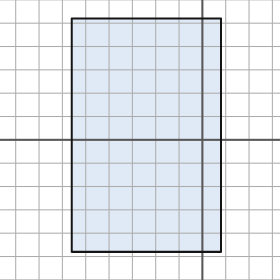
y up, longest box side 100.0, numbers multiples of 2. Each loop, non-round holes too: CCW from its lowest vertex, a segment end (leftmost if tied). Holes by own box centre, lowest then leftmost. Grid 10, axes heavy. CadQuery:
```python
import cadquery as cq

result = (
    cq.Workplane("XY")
    .moveTo(-56.0, -48.0)
    .lineTo(8.0, -48.0)
    .lineTo(8.0, 52.0)
    .lineTo(-56.0, 52.0)
    .close()
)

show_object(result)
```